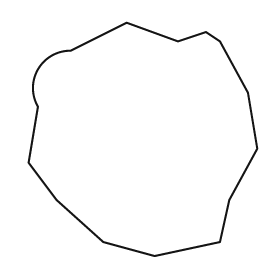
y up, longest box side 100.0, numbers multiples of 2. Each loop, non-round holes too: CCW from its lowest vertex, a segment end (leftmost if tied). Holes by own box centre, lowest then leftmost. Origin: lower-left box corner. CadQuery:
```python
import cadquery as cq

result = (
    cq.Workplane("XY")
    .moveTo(54.0, 0.0)
    .lineTo(82.0, 6.0)
    .lineTo(86.0, 24.0)
    .lineTo(98.0, 46.0)
    .lineTo(94.0, 70.0)
    .lineTo(82.0, 92.0)
    .lineTo(76.0, 96.0)
    .lineTo(64.0, 92.0)
    .lineTo(42.0, 100.0)
    .lineTo(18.0, 88.0)
    .threePointArc((4.0, 80.0), (4.0, 64.0))
    .lineTo(0.0, 40.0)
    .lineTo(12.0, 24.0)
    .lineTo(32.0, 6.0)
    .close()
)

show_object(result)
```